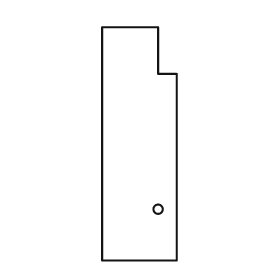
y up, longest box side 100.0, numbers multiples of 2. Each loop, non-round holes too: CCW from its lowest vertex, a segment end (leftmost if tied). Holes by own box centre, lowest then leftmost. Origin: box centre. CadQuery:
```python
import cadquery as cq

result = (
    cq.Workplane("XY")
    .moveTo(-16.0, -50.0)
    .lineTo(16.0, -50.0)
    .lineTo(16.0, 30.0)
    .lineTo(8.0, 30.0)
    .lineTo(8.0, 50.0)
    .lineTo(-16.0, 50.0)
    .close()
    .moveTo(8.0, -28.0)
    .circle(2.0)
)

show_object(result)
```